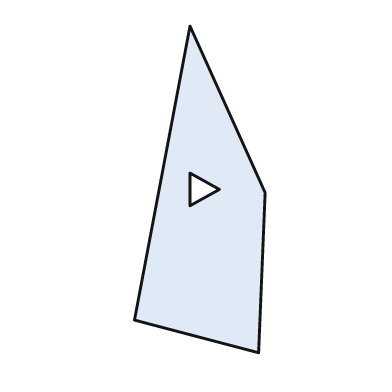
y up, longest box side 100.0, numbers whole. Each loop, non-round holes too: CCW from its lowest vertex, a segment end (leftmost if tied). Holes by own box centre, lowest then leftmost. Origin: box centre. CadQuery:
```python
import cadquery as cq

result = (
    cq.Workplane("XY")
    .moveTo(18.0, -50.0)
    .lineTo(20.0, -1.0)
    .lineTo(-3.0, 50.0)
    .lineTo(-20.0, -40.0)
    .close()
    .moveTo(-3.0, -5.0)
    .lineTo(6.0, 0.0)
    .lineTo(-3.0, 5.0)
    .close()
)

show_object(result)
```